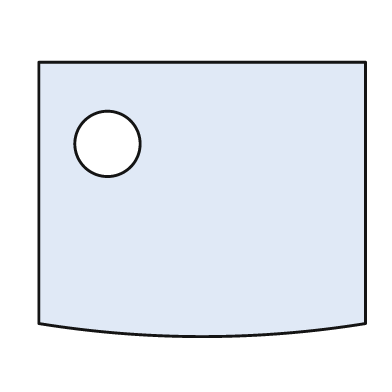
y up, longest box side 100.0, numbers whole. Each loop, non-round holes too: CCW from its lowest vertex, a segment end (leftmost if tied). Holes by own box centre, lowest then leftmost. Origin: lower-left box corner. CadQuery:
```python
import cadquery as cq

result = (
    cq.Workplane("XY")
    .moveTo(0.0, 4.0)
    .threePointArc((50.0, 0.0), (100.0, 4.0))
    .lineTo(100.0, 84.0)
    .lineTo(0.0, 84.0)
    .close()
    .moveTo(21.0, 59.0)
    .circle(10.0)
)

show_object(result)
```